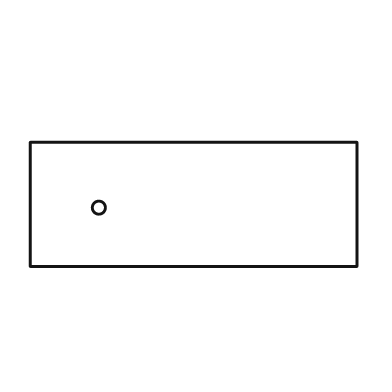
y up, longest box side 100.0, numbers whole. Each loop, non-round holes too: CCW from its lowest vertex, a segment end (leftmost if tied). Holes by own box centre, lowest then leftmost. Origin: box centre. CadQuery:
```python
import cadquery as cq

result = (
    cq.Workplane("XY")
    .moveTo(-50.0, -19.0)
    .lineTo(50.0, -19.0)
    .lineTo(50.0, 19.0)
    .lineTo(-50.0, 19.0)
    .close()
    .moveTo(-29.0, -1.0)
    .circle(2.0)
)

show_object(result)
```